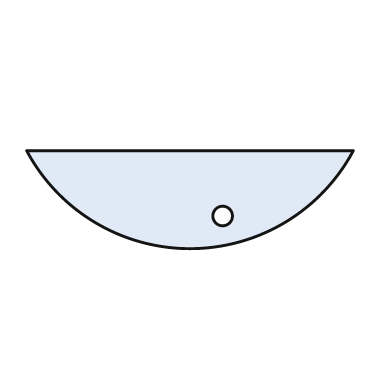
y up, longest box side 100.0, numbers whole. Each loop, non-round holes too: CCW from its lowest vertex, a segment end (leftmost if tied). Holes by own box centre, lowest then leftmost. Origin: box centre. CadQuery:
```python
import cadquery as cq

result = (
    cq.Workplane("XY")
    .moveTo(-50.0, 15.0)
    .threePointArc((0.0, -15.0), (50.0, 15.0))
    .close()
    .moveTo(10.0, -5.0)
    .circle(3.0)
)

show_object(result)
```